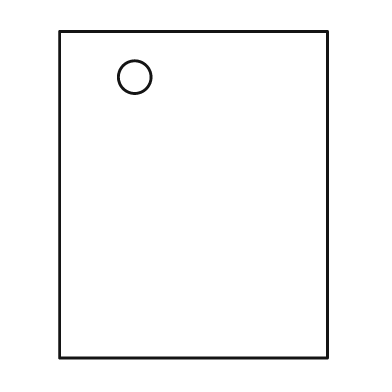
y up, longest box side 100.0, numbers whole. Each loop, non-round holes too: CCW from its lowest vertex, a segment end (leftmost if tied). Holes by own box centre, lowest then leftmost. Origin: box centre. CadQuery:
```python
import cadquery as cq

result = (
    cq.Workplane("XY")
    .moveTo(-41.0, -50.0)
    .lineTo(41.0, -50.0)
    .lineTo(41.0, 50.0)
    .lineTo(-41.0, 50.0)
    .close()
    .moveTo(-18.0, 36.0)
    .circle(5.0)
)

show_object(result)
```